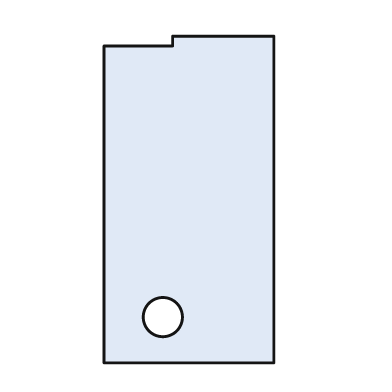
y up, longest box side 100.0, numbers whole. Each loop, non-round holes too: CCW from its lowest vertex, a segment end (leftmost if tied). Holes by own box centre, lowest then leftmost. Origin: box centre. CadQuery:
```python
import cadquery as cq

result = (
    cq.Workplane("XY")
    .moveTo(-26.0, -50.0)
    .lineTo(26.0, -50.0)
    .lineTo(26.0, 50.0)
    .lineTo(-5.0, 50.0)
    .lineTo(-5.0, 47.0)
    .lineTo(-26.0, 47.0)
    .close()
    .moveTo(-8.0, -36.0)
    .circle(6.0)
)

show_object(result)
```